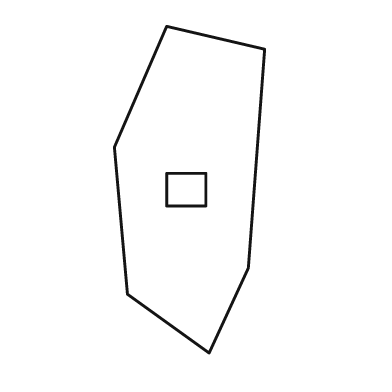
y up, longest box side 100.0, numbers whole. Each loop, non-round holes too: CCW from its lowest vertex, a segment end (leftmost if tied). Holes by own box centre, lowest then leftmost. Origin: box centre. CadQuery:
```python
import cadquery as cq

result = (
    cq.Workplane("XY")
    .moveTo(6.0, -50.0)
    .lineTo(18.0, -24.0)
    .lineTo(23.0, 43.0)
    .lineTo(-7.0, 50.0)
    .lineTo(-23.0, 13.0)
    .lineTo(-19.0, -32.0)
    .close()
    .moveTo(-7.0, -5.0)
    .lineTo(5.0, -5.0)
    .lineTo(5.0, 5.0)
    .lineTo(-7.0, 5.0)
    .close()
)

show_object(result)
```